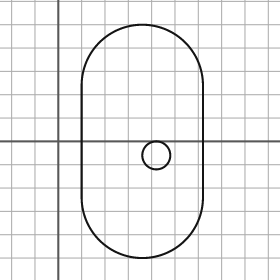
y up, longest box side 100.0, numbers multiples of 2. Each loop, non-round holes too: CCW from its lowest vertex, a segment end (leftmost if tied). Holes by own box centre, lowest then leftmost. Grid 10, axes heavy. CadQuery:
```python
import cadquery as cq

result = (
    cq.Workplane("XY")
    .moveTo(10.0, -24.0)
    .threePointArc((36.0, -50.0), (62.0, -24.0))
    .lineTo(62.0, 24.0)
    .threePointArc((36.0, 50.0), (10.0, 24.0))
    .close()
    .moveTo(42.0, -6.0)
    .circle(6.0)
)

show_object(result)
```